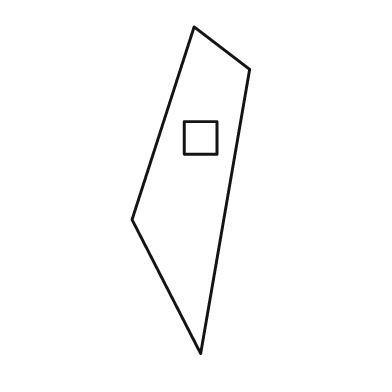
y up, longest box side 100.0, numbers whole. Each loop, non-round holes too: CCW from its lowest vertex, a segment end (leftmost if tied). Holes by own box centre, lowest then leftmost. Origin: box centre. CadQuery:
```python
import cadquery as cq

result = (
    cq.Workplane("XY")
    .moveTo(3.0, -50.0)
    .lineTo(18.0, 37.0)
    .lineTo(1.0, 50.0)
    .lineTo(-18.0, -9.0)
    .close()
    .moveTo(-2.0, 11.0)
    .lineTo(8.0, 11.0)
    .lineTo(8.0, 21.0)
    .lineTo(-2.0, 21.0)
    .close()
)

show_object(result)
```